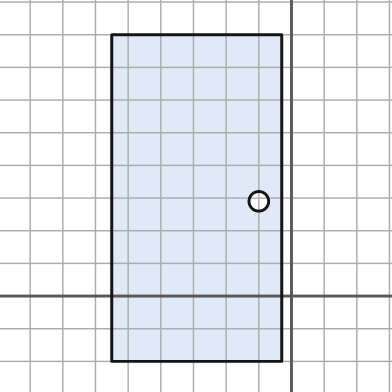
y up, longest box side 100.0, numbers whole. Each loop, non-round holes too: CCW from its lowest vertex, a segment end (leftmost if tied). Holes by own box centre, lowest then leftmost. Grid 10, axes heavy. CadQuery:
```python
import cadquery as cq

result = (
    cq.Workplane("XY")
    .moveTo(-55.0, -20.0)
    .lineTo(-3.0, -20.0)
    .lineTo(-3.0, 80.0)
    .lineTo(-55.0, 80.0)
    .close()
    .moveTo(-10.0, 29.0)
    .circle(3.0)
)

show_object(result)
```